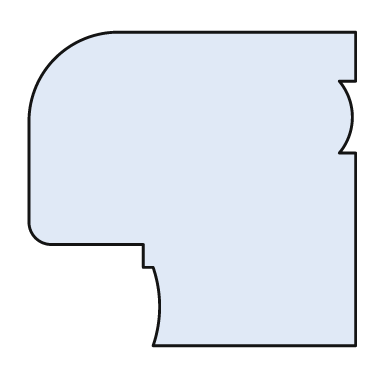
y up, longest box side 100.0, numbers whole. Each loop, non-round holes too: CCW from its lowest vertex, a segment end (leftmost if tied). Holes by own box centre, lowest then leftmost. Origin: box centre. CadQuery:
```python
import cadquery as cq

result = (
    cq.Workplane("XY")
    .moveTo(-12.0, -48.0)
    .lineTo(50.0, -48.0)
    .lineTo(50.0, 11.0)
    .lineTo(45.0, 11.0)
    .threePointArc((49.0, 22.0), (45.0, 33.0))
    .lineTo(50.0, 33.0)
    .lineTo(50.0, 48.0)
    .lineTo(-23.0, 48.0)
    .threePointArc((-42.0, 40.0), (-50.0, 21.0))
    .lineTo(-50.0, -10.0)
    .threePointArc((-48.0, -15.0), (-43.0, -17.0))
    .lineTo(-15.0, -17.0)
    .lineTo(-15.0, -24.0)
    .lineTo(-12.0, -24.0)
    .threePointArc((-10.0, -36.0), (-12.0, -48.0))
    .close()
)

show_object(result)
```